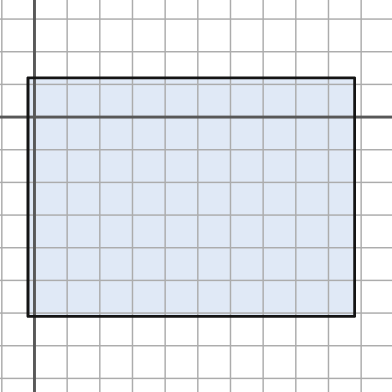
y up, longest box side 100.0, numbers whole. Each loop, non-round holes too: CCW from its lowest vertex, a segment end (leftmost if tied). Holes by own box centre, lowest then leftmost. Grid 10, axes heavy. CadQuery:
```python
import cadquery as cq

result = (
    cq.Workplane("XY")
    .moveTo(-2.0, -61.0)
    .lineTo(98.0, -61.0)
    .lineTo(98.0, 12.0)
    .lineTo(-2.0, 12.0)
    .close()
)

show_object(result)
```